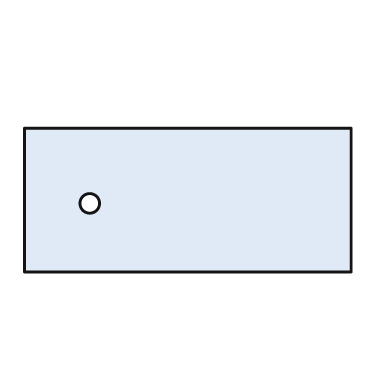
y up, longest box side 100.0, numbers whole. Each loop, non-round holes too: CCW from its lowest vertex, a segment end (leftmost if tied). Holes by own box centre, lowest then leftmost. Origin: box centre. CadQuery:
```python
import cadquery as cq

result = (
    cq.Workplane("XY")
    .moveTo(-50.0, -22.0)
    .lineTo(50.0, -22.0)
    .lineTo(50.0, 22.0)
    .lineTo(-50.0, 22.0)
    .close()
    .moveTo(-30.0, -1.0)
    .circle(3.0)
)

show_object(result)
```